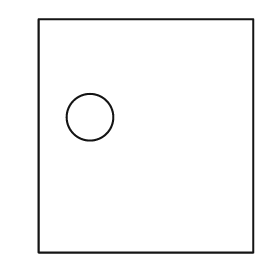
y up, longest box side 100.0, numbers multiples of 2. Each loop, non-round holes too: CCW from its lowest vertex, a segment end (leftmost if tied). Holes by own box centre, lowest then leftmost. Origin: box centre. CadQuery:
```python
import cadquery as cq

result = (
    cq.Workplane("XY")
    .moveTo(-46.0, -50.0)
    .lineTo(46.0, -50.0)
    .lineTo(46.0, 50.0)
    .lineTo(-46.0, 50.0)
    .close()
    .moveTo(-24.0, 8.0)
    .circle(10.0)
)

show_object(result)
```